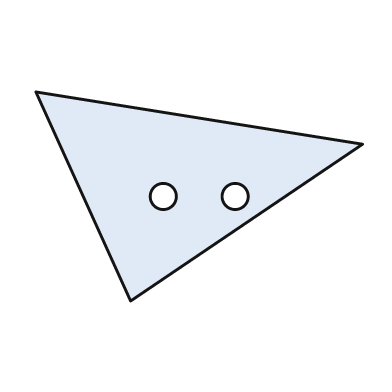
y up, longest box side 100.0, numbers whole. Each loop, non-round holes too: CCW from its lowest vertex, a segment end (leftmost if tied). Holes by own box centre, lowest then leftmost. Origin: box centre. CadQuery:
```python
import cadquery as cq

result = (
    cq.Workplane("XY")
    .moveTo(-21.0, -32.0)
    .lineTo(50.0, 16.0)
    .lineTo(-50.0, 32.0)
    .close()
    .moveTo(-11.0, 0.0)
    .circle(4.0)
    .moveTo(11.0, 0.0)
    .circle(4.0)
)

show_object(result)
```